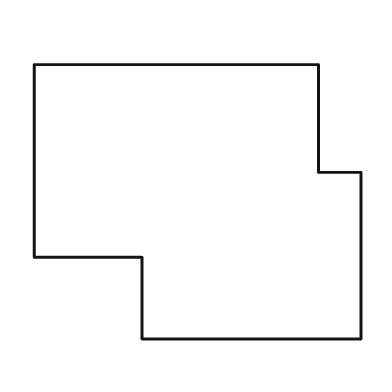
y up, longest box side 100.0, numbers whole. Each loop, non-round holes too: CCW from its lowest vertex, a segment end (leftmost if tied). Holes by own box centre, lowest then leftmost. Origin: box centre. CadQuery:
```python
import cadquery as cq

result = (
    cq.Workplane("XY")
    .moveTo(-17.0, -42.0)
    .lineTo(50.0, -42.0)
    .lineTo(50.0, 9.0)
    .lineTo(37.0, 9.0)
    .lineTo(37.0, 42.0)
    .lineTo(-50.0, 42.0)
    .lineTo(-50.0, -17.0)
    .lineTo(-17.0, -17.0)
    .close()
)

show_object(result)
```